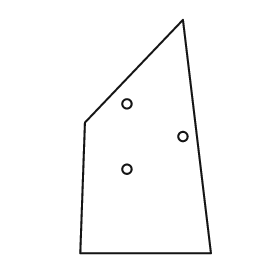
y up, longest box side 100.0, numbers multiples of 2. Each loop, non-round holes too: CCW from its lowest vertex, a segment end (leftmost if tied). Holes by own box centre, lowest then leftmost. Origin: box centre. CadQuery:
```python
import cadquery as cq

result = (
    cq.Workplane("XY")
    .moveTo(-28.0, -50.0)
    .lineTo(28.0, -50.0)
    .lineTo(16.0, 50.0)
    .lineTo(-26.0, 6.0)
    .close()
    .moveTo(-8.0, -14.0)
    .circle(2.0)
    .moveTo(16.0, 0.0)
    .circle(2.0)
    .moveTo(-8.0, 14.0)
    .circle(2.0)
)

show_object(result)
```